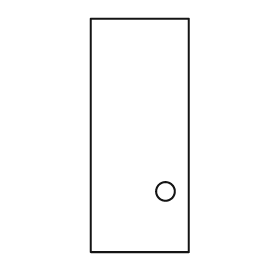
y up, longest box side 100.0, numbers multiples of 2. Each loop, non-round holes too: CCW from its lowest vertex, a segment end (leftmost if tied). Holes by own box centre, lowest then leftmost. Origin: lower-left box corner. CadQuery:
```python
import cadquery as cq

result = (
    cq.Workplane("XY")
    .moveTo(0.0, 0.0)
    .lineTo(42.0, 0.0)
    .lineTo(42.0, 100.0)
    .lineTo(0.0, 100.0)
    .close()
    .moveTo(32.0, 26.0)
    .circle(4.0)
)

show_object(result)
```